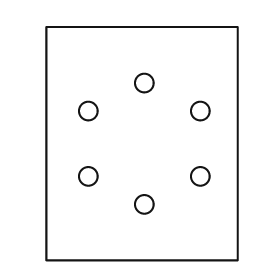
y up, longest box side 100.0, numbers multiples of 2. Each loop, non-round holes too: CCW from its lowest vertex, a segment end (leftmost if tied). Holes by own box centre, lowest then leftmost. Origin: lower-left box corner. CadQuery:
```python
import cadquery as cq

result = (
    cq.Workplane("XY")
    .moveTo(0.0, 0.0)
    .lineTo(82.0, 0.0)
    .lineTo(82.0, 100.0)
    .lineTo(0.0, 100.0)
    .close()
    .moveTo(42.0, 24.0)
    .circle(4.0)
    .moveTo(18.0, 36.0)
    .circle(4.0)
    .moveTo(66.0, 36.0)
    .circle(4.0)
    .moveTo(18.0, 64.0)
    .circle(4.0)
    .moveTo(66.0, 64.0)
    .circle(4.0)
    .moveTo(42.0, 76.0)
    .circle(4.0)
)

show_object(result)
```